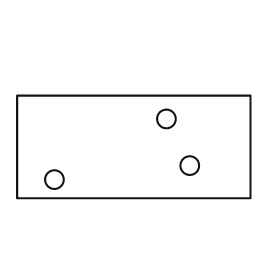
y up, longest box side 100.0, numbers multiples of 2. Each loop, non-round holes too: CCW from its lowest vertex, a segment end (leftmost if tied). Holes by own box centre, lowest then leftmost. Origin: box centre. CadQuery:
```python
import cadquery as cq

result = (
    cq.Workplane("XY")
    .moveTo(-50.0, -22.0)
    .lineTo(50.0, -22.0)
    .lineTo(50.0, 22.0)
    .lineTo(-50.0, 22.0)
    .close()
    .moveTo(-34.0, -14.0)
    .circle(4.0)
    .moveTo(24.0, -8.0)
    .circle(4.0)
    .moveTo(14.0, 12.0)
    .circle(4.0)
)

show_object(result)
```